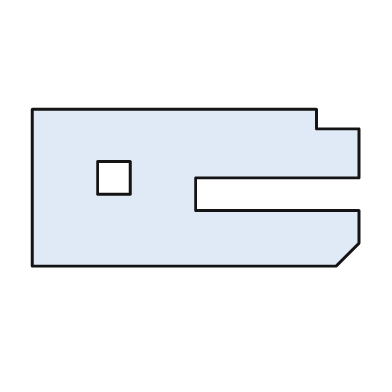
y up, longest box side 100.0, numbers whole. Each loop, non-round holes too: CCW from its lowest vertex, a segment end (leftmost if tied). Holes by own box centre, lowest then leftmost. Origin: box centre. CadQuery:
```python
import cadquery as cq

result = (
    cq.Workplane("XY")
    .moveTo(-50.0, -24.0)
    .lineTo(43.0, -24.0)
    .lineTo(50.0, -17.0)
    .lineTo(50.0, -7.0)
    .lineTo(0.0, -7.0)
    .lineTo(0.0, 3.0)
    .lineTo(50.0, 3.0)
    .lineTo(50.0, 18.0)
    .lineTo(37.0, 18.0)
    .lineTo(37.0, 24.0)
    .lineTo(-50.0, 24.0)
    .close()
    .moveTo(-30.0, -2.0)
    .lineTo(-20.0, -2.0)
    .lineTo(-20.0, 8.0)
    .lineTo(-30.0, 8.0)
    .close()
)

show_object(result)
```